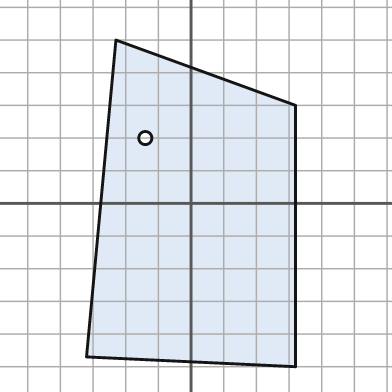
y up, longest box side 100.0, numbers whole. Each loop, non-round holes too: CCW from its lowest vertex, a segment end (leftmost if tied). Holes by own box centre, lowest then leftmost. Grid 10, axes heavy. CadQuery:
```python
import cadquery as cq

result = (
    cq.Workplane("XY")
    .moveTo(32.0, -50.0)
    .lineTo(32.0, 30.0)
    .lineTo(-23.0, 50.0)
    .lineTo(-32.0, -47.0)
    .close()
    .moveTo(-14.0, 20.0)
    .circle(2.0)
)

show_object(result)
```